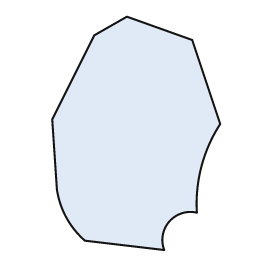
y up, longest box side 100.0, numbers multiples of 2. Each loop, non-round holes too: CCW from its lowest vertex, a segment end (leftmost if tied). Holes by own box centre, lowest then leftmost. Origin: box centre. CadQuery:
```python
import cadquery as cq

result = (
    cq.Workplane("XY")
    .moveTo(12.0, -50.0)
    .threePointArc((14.0, -38.0), (26.0, -34.0))
    .threePointArc((28.0, -14.0), (36.0, 4.0))
    .lineTo(24.0, 40.0)
    .lineTo(-4.0, 50.0)
    .lineTo(-18.0, 42.0)
    .lineTo(-36.0, 6.0)
    .lineTo(-34.0, -24.0)
    .threePointArc((-30.0, -36.0), (-22.0, -46.0))
    .close()
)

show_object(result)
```